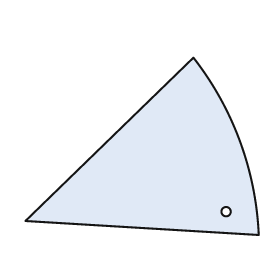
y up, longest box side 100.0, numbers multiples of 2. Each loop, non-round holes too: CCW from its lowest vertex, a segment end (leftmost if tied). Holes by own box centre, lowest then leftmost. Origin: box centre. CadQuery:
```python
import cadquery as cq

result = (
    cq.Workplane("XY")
    .moveTo(50.0, -38.0)
    .threePointArc((42.0, 2.0), (22.0, 38.0))
    .lineTo(-50.0, -32.0)
    .close()
    .moveTo(36.0, -28.0)
    .circle(2.0)
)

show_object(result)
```